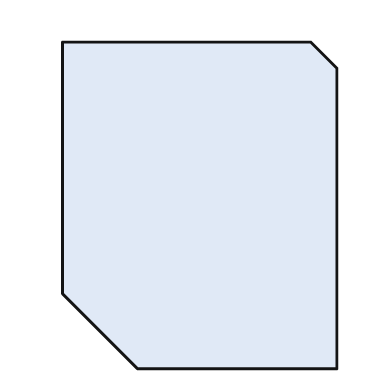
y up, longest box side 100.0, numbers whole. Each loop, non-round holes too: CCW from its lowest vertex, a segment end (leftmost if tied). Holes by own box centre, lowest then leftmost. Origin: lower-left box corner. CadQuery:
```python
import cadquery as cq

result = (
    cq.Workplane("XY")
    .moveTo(23.0, 0.0)
    .lineTo(84.0, 0.0)
    .lineTo(84.0, 92.0)
    .lineTo(76.0, 100.0)
    .lineTo(0.0, 100.0)
    .lineTo(0.0, 23.0)
    .close()
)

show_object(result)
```